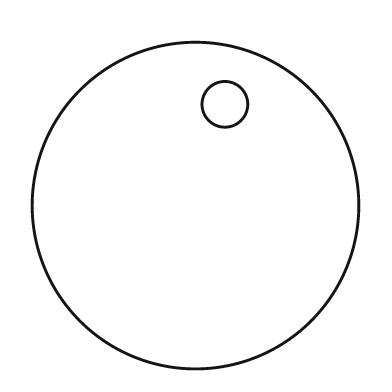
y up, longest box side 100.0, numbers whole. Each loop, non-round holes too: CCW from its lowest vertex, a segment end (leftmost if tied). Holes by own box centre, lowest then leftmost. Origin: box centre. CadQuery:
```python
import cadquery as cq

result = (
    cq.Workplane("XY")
    .moveTo(0.0, 0.0)
    .circle(50.0)
    .moveTo(9.0, 31.0)
    .circle(7.0)
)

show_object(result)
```